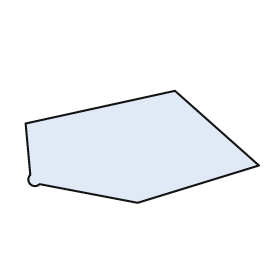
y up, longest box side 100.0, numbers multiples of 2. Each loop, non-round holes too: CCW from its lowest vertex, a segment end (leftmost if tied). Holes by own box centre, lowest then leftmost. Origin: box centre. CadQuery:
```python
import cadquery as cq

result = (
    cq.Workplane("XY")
    .moveTo(-2.0, -24.0)
    .lineTo(50.0, -8.0)
    .lineTo(14.0, 24.0)
    .lineTo(-50.0, 10.0)
    .lineTo(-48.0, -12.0)
    .threePointArc((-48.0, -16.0), (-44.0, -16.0))
    .close()
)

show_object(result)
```